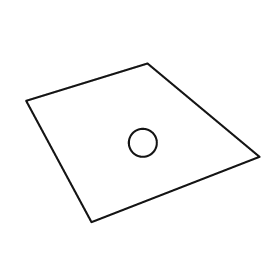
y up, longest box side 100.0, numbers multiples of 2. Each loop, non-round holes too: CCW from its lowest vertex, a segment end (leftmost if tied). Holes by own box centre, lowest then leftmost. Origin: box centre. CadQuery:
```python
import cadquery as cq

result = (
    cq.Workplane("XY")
    .moveTo(-22.0, -34.0)
    .lineTo(50.0, -6.0)
    .lineTo(2.0, 34.0)
    .lineTo(-50.0, 18.0)
    .close()
    .moveTo(0.0, 0.0)
    .circle(6.0)
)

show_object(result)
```